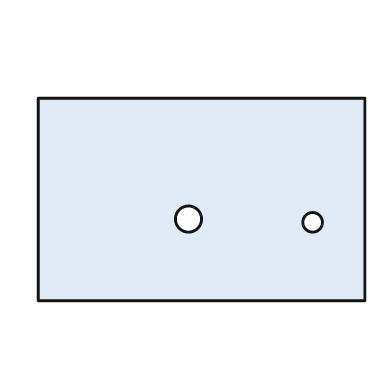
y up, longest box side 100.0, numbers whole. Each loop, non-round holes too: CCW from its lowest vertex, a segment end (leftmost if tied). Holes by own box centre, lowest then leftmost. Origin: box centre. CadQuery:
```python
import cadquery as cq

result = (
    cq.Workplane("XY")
    .moveTo(-50.0, -31.0)
    .lineTo(50.0, -31.0)
    .lineTo(50.0, 31.0)
    .lineTo(-50.0, 31.0)
    .close()
    .moveTo(34.0, -7.0)
    .circle(3.0)
    .moveTo(-4.0, -6.0)
    .circle(4.0)
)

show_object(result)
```